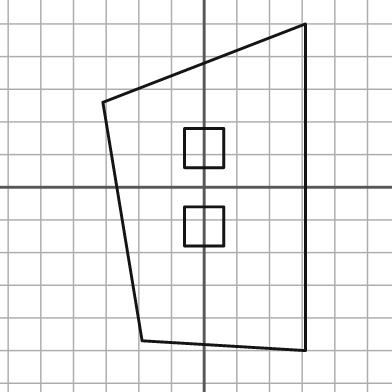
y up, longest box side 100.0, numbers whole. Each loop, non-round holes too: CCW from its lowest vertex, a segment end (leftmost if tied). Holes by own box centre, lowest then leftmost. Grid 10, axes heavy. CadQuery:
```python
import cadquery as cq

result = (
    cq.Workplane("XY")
    .moveTo(31.0, -50.0)
    .lineTo(31.0, 50.0)
    .lineTo(-31.0, 26.0)
    .lineTo(-19.0, -47.0)
    .close()
    .moveTo(-6.0, -18.0)
    .lineTo(6.0, -18.0)
    .lineTo(6.0, -6.0)
    .lineTo(-6.0, -6.0)
    .close()
    .moveTo(-6.0, 6.0)
    .lineTo(6.0, 6.0)
    .lineTo(6.0, 18.0)
    .lineTo(-6.0, 18.0)
    .close()
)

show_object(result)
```